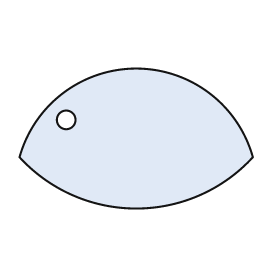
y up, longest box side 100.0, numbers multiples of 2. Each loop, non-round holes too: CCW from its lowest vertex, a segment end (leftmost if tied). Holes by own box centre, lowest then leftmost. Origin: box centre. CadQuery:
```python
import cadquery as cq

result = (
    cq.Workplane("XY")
    .moveTo(-50.0, -8.0)
    .threePointArc((0.0, -30.0), (50.0, -8.0))
    .threePointArc((0.0, 30.0), (-50.0, -8.0))
    .close()
    .moveTo(-30.0, 8.0)
    .circle(4.0)
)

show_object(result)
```